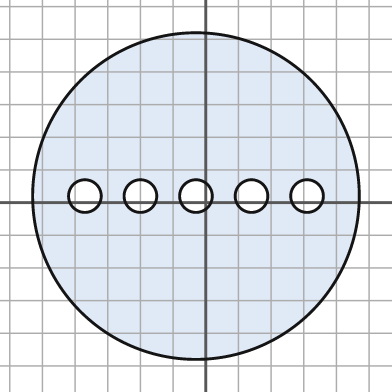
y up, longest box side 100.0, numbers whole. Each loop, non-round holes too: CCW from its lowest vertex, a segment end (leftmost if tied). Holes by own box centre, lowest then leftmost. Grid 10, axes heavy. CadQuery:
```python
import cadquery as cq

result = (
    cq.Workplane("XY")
    .moveTo(-3.0, 2.0)
    .circle(50.0)
    .moveTo(-37.0, 2.0)
    .circle(5.0)
    .moveTo(-20.0, 2.0)
    .circle(5.0)
    .moveTo(-3.0, 2.0)
    .circle(5.0)
    .moveTo(14.0, 2.0)
    .circle(5.0)
    .moveTo(31.0, 2.0)
    .circle(5.0)
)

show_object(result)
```